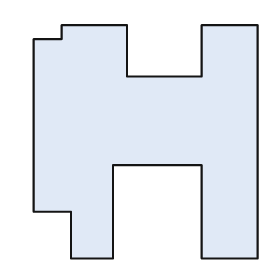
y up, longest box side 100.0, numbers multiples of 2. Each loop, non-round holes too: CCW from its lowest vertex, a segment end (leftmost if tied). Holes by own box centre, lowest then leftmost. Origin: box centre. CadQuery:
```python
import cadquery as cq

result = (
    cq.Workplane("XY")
    .moveTo(-32.0, -50.0)
    .lineTo(-14.0, -50.0)
    .lineTo(-14.0, -10.0)
    .lineTo(24.0, -10.0)
    .lineTo(24.0, -50.0)
    .lineTo(48.0, -50.0)
    .lineTo(48.0, 50.0)
    .lineTo(24.0, 50.0)
    .lineTo(24.0, 28.0)
    .lineTo(-8.0, 28.0)
    .lineTo(-8.0, 50.0)
    .lineTo(-36.0, 50.0)
    .lineTo(-36.0, 44.0)
    .lineTo(-48.0, 44.0)
    .lineTo(-48.0, -30.0)
    .lineTo(-32.0, -30.0)
    .close()
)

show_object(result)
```